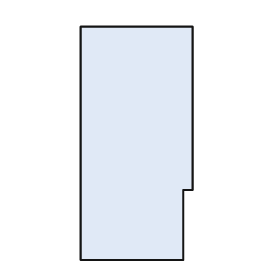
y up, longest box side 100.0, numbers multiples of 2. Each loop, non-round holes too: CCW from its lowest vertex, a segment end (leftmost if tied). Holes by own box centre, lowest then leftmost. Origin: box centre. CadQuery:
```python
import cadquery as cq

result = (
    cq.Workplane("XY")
    .moveTo(-24.0, -50.0)
    .lineTo(20.0, -50.0)
    .lineTo(20.0, -20.0)
    .lineTo(24.0, -20.0)
    .lineTo(24.0, 50.0)
    .lineTo(-24.0, 50.0)
    .close()
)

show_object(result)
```